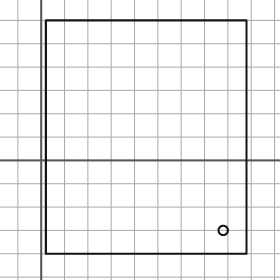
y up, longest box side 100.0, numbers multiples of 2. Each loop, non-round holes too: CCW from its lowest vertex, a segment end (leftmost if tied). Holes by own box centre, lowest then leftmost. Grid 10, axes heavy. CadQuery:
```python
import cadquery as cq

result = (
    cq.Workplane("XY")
    .moveTo(2.0, -40.0)
    .lineTo(88.0, -40.0)
    .lineTo(88.0, 60.0)
    .lineTo(2.0, 60.0)
    .close()
    .moveTo(78.0, -30.0)
    .circle(2.0)
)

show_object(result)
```